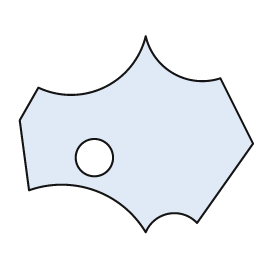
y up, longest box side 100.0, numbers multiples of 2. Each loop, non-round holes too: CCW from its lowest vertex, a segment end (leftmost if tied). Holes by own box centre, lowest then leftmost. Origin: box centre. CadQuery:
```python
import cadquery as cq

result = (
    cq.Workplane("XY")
    .moveTo(4.0, -42.0)
    .threePointArc((14.0, -34.0), (26.0, -38.0))
    .lineTo(50.0, -4.0)
    .lineTo(36.0, 24.0)
    .threePointArc((16.0, 26.0), (4.0, 42.0))
    .threePointArc((-14.0, 20.0), (-42.0, 20.0))
    .lineTo(-50.0, 6.0)
    .lineTo(-46.0, -24.0)
    .threePointArc((-18.0, -24.0), (4.0, -42.0))
    .close()
    .moveTo(-18.0, -10.0)
    .circle(8.0)
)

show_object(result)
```